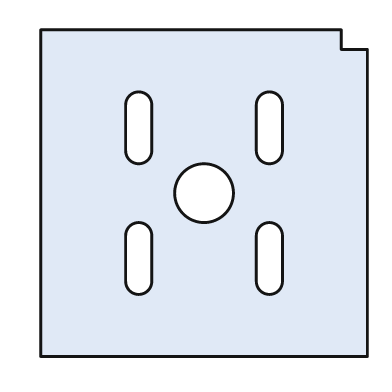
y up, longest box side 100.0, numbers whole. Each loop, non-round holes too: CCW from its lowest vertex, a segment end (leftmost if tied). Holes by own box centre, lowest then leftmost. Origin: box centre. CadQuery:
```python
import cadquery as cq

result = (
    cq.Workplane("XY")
    .moveTo(-50.0, -50.0)
    .lineTo(50.0, -50.0)
    .lineTo(50.0, 44.0)
    .lineTo(42.0, 44.0)
    .lineTo(42.0, 50.0)
    .lineTo(-50.0, 50.0)
    .close()
    .moveTo(-24.0, -27.0)
    .threePointArc((-20.0, -31.0), (-16.0, -27.0))
    .lineTo(-16.0, -13.0)
    .threePointArc((-20.0, -9.0), (-24.0, -13.0))
    .close()
    .moveTo(16.0, -27.0)
    .threePointArc((20.0, -31.0), (24.0, -27.0))
    .lineTo(24.0, -13.0)
    .threePointArc((20.0, -9.0), (16.0, -13.0))
    .close()
    .moveTo(0.0, 0.0)
    .circle(9.0)
    .moveTo(-24.0, 13.0)
    .threePointArc((-20.0, 9.0), (-16.0, 13.0))
    .lineTo(-16.0, 27.0)
    .threePointArc((-20.0, 31.0), (-24.0, 27.0))
    .close()
    .moveTo(16.0, 13.0)
    .threePointArc((20.0, 9.0), (24.0, 13.0))
    .lineTo(24.0, 27.0)
    .threePointArc((20.0, 31.0), (16.0, 27.0))
    .close()
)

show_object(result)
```